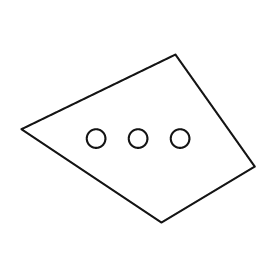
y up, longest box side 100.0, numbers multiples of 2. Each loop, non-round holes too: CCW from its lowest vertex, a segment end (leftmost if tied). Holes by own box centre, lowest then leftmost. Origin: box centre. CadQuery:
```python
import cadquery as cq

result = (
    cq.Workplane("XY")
    .moveTo(10.0, -36.0)
    .lineTo(50.0, -12.0)
    .lineTo(16.0, 36.0)
    .lineTo(-50.0, 4.0)
    .close()
    .moveTo(-18.0, 0.0)
    .circle(4.0)
    .moveTo(0.0, 0.0)
    .circle(4.0)
    .moveTo(18.0, 0.0)
    .circle(4.0)
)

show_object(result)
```